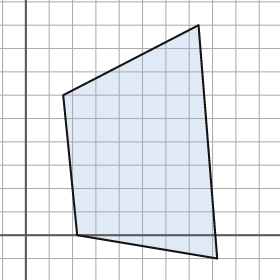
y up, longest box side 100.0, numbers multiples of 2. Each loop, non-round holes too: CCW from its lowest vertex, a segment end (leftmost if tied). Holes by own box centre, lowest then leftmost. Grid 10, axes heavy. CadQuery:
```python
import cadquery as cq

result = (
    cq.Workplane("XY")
    .moveTo(82.0, -10.0)
    .lineTo(74.0, 90.0)
    .lineTo(16.0, 60.0)
    .lineTo(22.0, 0.0)
    .close()
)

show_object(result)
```